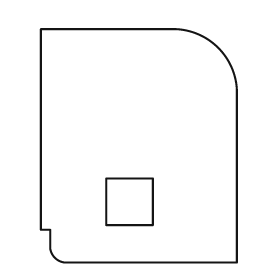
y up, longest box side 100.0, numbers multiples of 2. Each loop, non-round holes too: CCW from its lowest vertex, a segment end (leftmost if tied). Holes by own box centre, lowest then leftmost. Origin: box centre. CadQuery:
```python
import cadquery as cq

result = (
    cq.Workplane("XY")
    .moveTo(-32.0, -50.0)
    .lineTo(42.0, -50.0)
    .lineTo(42.0, 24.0)
    .threePointArc((34.0, 42.0), (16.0, 50.0))
    .lineTo(-42.0, 50.0)
    .lineTo(-42.0, -36.0)
    .lineTo(-38.0, -36.0)
    .lineTo(-38.0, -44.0)
    .threePointArc((-36.0, -48.0), (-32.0, -50.0))
    .close()
    .moveTo(-14.0, -34.0)
    .lineTo(6.0, -34.0)
    .lineTo(6.0, -14.0)
    .lineTo(-14.0, -14.0)
    .close()
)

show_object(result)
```